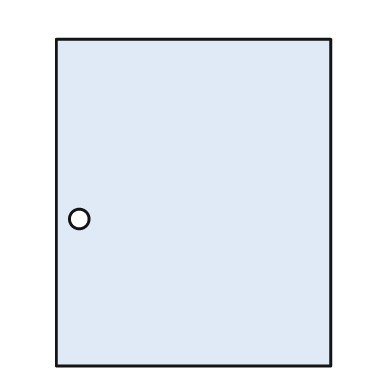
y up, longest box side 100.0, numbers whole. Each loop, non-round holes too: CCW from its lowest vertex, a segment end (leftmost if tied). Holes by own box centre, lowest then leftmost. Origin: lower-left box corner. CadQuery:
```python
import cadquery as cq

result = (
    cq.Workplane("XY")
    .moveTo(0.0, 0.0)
    .lineTo(84.0, 0.0)
    .lineTo(84.0, 100.0)
    .lineTo(0.0, 100.0)
    .close()
    .moveTo(7.0, 45.0)
    .circle(3.0)
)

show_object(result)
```